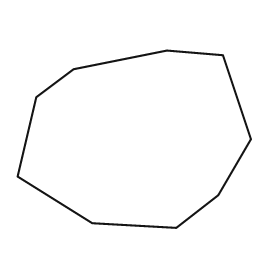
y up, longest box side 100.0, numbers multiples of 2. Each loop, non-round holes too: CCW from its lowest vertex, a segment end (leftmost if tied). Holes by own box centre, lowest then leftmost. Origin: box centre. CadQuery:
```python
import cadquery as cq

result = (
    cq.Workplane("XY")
    .moveTo(18.0, -38.0)
    .lineTo(36.0, -24.0)
    .lineTo(50.0, 0.0)
    .lineTo(38.0, 36.0)
    .lineTo(14.0, 38.0)
    .lineTo(-26.0, 30.0)
    .lineTo(-42.0, 18.0)
    .lineTo(-50.0, -16.0)
    .lineTo(-18.0, -36.0)
    .close()
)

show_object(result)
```